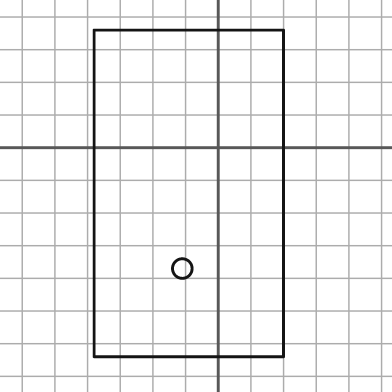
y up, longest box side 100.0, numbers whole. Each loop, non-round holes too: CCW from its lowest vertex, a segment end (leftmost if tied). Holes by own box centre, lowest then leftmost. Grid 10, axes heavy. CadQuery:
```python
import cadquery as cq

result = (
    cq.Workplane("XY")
    .moveTo(-38.0, -64.0)
    .lineTo(20.0, -64.0)
    .lineTo(20.0, 36.0)
    .lineTo(-38.0, 36.0)
    .close()
    .moveTo(-11.0, -37.0)
    .circle(3.0)
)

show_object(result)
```